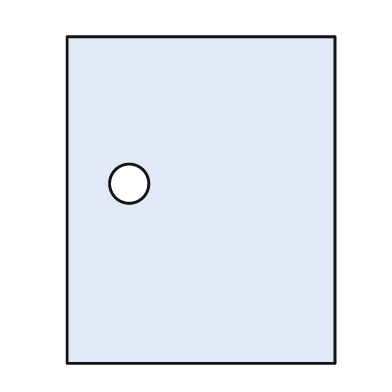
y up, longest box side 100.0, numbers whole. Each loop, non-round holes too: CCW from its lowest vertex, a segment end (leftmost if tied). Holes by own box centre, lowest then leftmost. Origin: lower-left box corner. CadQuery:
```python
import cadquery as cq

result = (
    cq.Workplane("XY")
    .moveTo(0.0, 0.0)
    .lineTo(82.0, 0.0)
    .lineTo(82.0, 100.0)
    .lineTo(0.0, 100.0)
    .close()
    .moveTo(19.0, 55.0)
    .circle(6.0)
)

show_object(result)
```